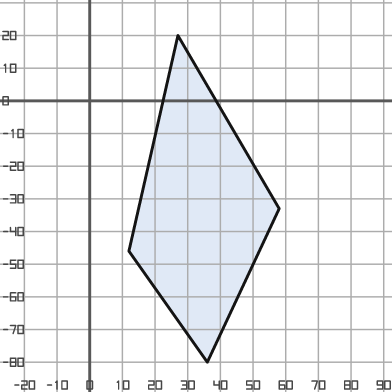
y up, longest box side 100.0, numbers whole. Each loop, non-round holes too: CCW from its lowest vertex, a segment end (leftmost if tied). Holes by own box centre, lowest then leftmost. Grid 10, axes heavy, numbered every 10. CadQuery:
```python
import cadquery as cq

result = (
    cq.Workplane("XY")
    .moveTo(36.0, -80.0)
    .lineTo(58.0, -33.0)
    .lineTo(27.0, 20.0)
    .lineTo(12.0, -46.0)
    .close()
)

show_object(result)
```